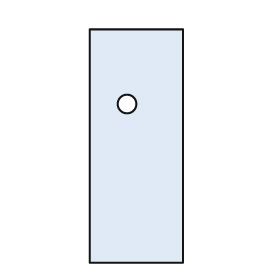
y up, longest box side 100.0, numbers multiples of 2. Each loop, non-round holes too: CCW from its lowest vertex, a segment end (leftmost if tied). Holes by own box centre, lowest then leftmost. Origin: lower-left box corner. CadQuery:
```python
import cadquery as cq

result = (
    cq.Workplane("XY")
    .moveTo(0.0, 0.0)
    .lineTo(40.0, 0.0)
    .lineTo(40.0, 100.0)
    .lineTo(0.0, 100.0)
    .close()
    .moveTo(16.0, 68.0)
    .circle(4.0)
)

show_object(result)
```